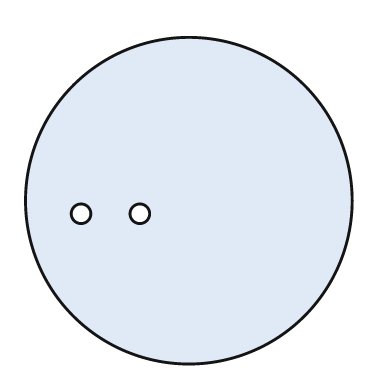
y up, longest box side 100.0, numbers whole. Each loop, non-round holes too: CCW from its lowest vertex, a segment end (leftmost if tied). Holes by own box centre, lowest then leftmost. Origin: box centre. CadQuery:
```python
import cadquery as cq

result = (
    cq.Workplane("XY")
    .moveTo(0.0, 0.0)
    .circle(50.0)
    .moveTo(-33.0, -4.0)
    .circle(3.0)
    .moveTo(-15.0, -4.0)
    .circle(3.0)
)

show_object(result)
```